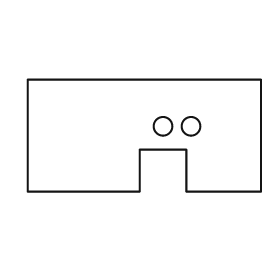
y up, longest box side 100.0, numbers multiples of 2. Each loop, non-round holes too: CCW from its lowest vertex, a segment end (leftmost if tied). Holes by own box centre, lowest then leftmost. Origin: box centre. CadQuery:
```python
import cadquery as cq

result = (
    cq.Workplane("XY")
    .moveTo(-50.0, -24.0)
    .lineTo(-2.0, -24.0)
    .lineTo(-2.0, -6.0)
    .lineTo(18.0, -6.0)
    .lineTo(18.0, -24.0)
    .lineTo(50.0, -24.0)
    .lineTo(50.0, 24.0)
    .lineTo(-50.0, 24.0)
    .close()
    .moveTo(8.0, 4.0)
    .circle(4.0)
    .moveTo(20.0, 4.0)
    .circle(4.0)
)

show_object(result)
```